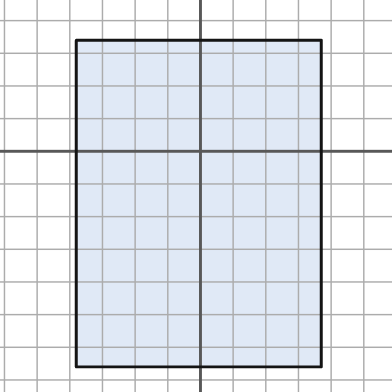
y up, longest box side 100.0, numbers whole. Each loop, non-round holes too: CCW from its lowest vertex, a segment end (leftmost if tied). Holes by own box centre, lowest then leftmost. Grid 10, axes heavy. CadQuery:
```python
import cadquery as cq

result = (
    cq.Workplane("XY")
    .moveTo(-38.0, -66.0)
    .lineTo(37.0, -66.0)
    .lineTo(37.0, 34.0)
    .lineTo(-38.0, 34.0)
    .close()
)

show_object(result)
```